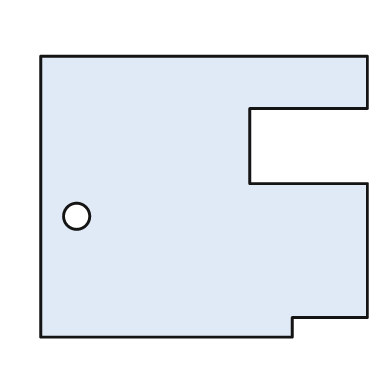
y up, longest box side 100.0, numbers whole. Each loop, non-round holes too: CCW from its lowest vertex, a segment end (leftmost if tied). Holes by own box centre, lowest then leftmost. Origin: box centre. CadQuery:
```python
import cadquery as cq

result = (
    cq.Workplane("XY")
    .moveTo(-50.0, -43.0)
    .lineTo(27.0, -43.0)
    .lineTo(27.0, -37.0)
    .lineTo(50.0, -37.0)
    .lineTo(50.0, 4.0)
    .lineTo(14.0, 4.0)
    .lineTo(14.0, 27.0)
    .lineTo(50.0, 27.0)
    .lineTo(50.0, 43.0)
    .lineTo(-50.0, 43.0)
    .close()
    .moveTo(-39.0, -6.0)
    .circle(4.0)
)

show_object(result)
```